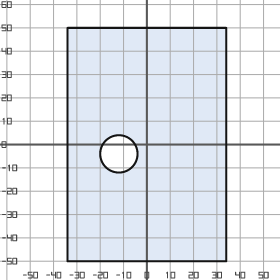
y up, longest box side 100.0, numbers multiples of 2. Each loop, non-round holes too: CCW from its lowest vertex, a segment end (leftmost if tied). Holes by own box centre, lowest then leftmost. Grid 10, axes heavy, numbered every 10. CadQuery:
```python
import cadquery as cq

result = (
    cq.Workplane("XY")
    .moveTo(-34.0, -50.0)
    .lineTo(34.0, -50.0)
    .lineTo(34.0, 50.0)
    .lineTo(-34.0, 50.0)
    .close()
    .moveTo(-12.0, -4.0)
    .circle(8.0)
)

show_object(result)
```